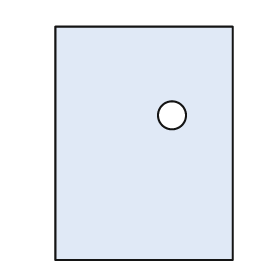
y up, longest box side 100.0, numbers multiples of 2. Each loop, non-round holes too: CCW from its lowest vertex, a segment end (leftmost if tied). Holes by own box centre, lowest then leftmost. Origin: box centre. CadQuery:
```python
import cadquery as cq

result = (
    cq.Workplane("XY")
    .moveTo(-38.0, -50.0)
    .lineTo(38.0, -50.0)
    .lineTo(38.0, 50.0)
    .lineTo(-38.0, 50.0)
    .close()
    .moveTo(12.0, 12.0)
    .circle(6.0)
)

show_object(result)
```